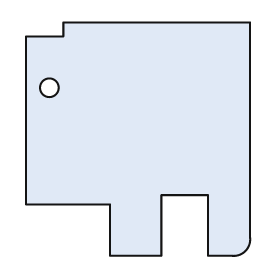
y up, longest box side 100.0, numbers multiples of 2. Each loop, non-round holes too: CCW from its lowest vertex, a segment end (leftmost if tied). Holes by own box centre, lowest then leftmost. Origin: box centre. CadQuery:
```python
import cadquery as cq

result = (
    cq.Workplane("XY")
    .moveTo(-12.0, -50.0)
    .lineTo(10.0, -50.0)
    .lineTo(10.0, -24.0)
    .lineTo(30.0, -24.0)
    .lineTo(30.0, -50.0)
    .lineTo(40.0, -50.0)
    .threePointArc((46.0, -48.0), (48.0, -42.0))
    .lineTo(48.0, 50.0)
    .lineTo(-32.0, 50.0)
    .lineTo(-32.0, 44.0)
    .lineTo(-48.0, 44.0)
    .lineTo(-48.0, -28.0)
    .lineTo(-12.0, -28.0)
    .close()
    .moveTo(-38.0, 22.0)
    .circle(4.0)
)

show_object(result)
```